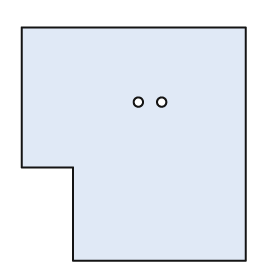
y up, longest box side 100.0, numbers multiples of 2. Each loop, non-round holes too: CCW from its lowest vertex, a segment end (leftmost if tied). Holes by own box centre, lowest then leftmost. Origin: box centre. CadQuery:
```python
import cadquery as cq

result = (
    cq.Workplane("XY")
    .moveTo(-26.0, -50.0)
    .lineTo(48.0, -50.0)
    .lineTo(48.0, 50.0)
    .lineTo(-48.0, 50.0)
    .lineTo(-48.0, -10.0)
    .lineTo(-26.0, -10.0)
    .close()
    .moveTo(2.0, 18.0)
    .circle(2.0)
    .moveTo(12.0, 18.0)
    .circle(2.0)
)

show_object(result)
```